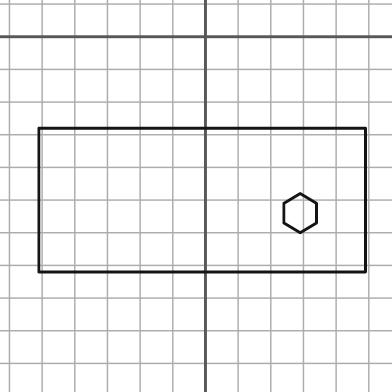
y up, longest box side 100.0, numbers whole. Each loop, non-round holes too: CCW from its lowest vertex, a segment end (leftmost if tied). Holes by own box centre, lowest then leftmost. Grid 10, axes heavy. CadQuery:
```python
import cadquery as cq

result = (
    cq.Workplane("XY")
    .moveTo(-51.0, -72.0)
    .lineTo(49.0, -72.0)
    .lineTo(49.0, -28.0)
    .lineTo(-51.0, -28.0)
    .close()
    .moveTo(29.0, -60.0)
    .lineTo(34.0, -57.0)
    .lineTo(34.0, -51.0)
    .lineTo(29.0, -48.0)
    .lineTo(24.0, -51.0)
    .lineTo(24.0, -57.0)
    .close()
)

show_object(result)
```